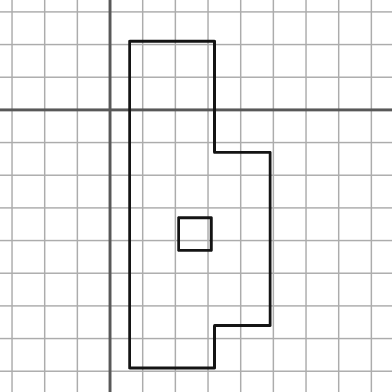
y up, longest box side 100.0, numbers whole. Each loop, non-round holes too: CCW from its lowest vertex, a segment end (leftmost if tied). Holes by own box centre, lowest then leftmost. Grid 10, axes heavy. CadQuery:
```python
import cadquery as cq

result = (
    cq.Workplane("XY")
    .moveTo(6.0, -79.0)
    .lineTo(32.0, -79.0)
    .lineTo(32.0, -66.0)
    .lineTo(49.0, -66.0)
    .lineTo(49.0, -13.0)
    .lineTo(32.0, -13.0)
    .lineTo(32.0, 21.0)
    .lineTo(6.0, 21.0)
    .close()
    .moveTo(21.0, -43.0)
    .lineTo(31.0, -43.0)
    .lineTo(31.0, -33.0)
    .lineTo(21.0, -33.0)
    .close()
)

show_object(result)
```